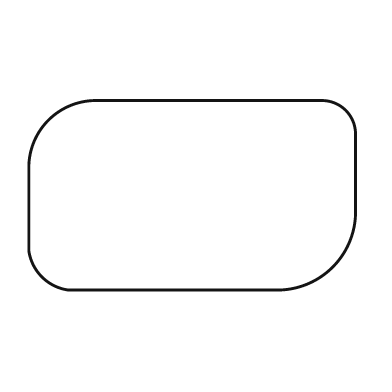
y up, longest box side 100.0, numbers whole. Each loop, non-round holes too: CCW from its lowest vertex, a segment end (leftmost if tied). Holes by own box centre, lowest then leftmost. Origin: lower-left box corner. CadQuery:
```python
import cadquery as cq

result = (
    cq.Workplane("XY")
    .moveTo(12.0, 0.0)
    .lineTo(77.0, 0.0)
    .threePointArc((93.0, 7.0), (100.0, 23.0))
    .lineTo(100.0, 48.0)
    .threePointArc((97.0, 55.0), (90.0, 58.0))
    .lineTo(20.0, 58.0)
    .threePointArc((6.0, 52.0), (0.0, 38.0))
    .lineTo(0.0, 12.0)
    .threePointArc((4.0, 4.0), (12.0, 0.0))
    .close()
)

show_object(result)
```